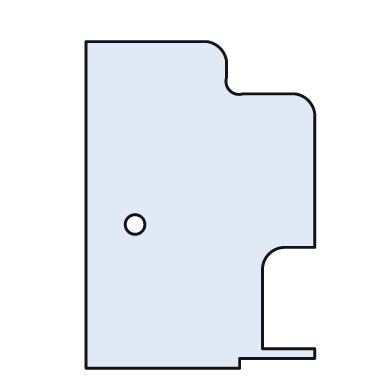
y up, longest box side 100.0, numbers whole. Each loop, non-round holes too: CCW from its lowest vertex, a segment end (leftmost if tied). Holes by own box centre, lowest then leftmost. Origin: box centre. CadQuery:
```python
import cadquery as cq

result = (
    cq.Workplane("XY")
    .moveTo(-35.0, -50.0)
    .lineTo(12.0, -50.0)
    .lineTo(12.0, -47.0)
    .lineTo(35.0, -47.0)
    .lineTo(35.0, -44.0)
    .lineTo(19.0, -44.0)
    .lineTo(19.0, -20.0)
    .threePointArc((21.0, -15.0), (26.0, -13.0))
    .lineTo(35.0, -13.0)
    .lineTo(35.0, 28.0)
    .threePointArc((33.0, 32.0), (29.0, 34.0))
    .lineTo(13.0, 34.0)
    .threePointArc((9.0, 35.0), (8.0, 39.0))
    .lineTo(8.0, 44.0)
    .threePointArc((6.0, 48.0), (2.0, 50.0))
    .lineTo(-35.0, 50.0)
    .close()
    .moveTo(-20.0, -6.0)
    .circle(3.0)
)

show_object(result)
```